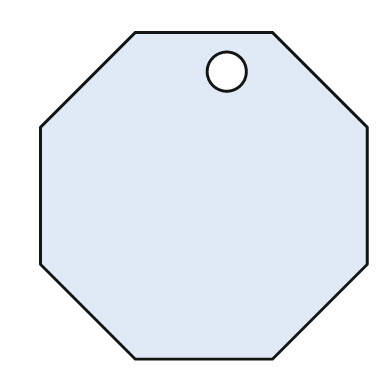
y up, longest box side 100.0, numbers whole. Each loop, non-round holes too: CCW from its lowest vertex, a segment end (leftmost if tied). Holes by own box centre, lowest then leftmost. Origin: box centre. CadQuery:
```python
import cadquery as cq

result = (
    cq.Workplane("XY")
    .moveTo(-21.0, -50.0)
    .lineTo(21.0, -50.0)
    .lineTo(50.0, -21.0)
    .lineTo(50.0, 21.0)
    .lineTo(21.0, 50.0)
    .lineTo(-21.0, 50.0)
    .lineTo(-50.0, 21.0)
    .lineTo(-50.0, -21.0)
    .close()
    .moveTo(7.0, 38.0)
    .circle(6.0)
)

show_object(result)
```